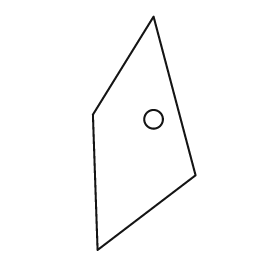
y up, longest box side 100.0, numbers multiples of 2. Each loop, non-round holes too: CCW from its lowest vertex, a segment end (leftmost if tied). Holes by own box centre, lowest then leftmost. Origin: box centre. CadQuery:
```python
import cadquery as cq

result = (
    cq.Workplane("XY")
    .moveTo(-20.0, -50.0)
    .lineTo(22.0, -18.0)
    .lineTo(4.0, 50.0)
    .lineTo(-22.0, 8.0)
    .close()
    .moveTo(4.0, 6.0)
    .circle(4.0)
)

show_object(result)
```